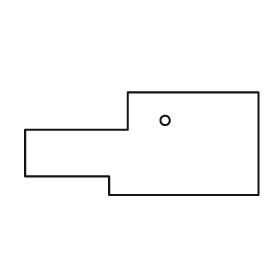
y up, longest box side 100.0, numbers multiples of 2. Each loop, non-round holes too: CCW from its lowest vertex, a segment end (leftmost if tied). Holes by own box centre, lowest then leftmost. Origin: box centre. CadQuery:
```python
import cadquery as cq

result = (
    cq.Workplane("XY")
    .moveTo(-14.0, -22.0)
    .lineTo(50.0, -22.0)
    .lineTo(50.0, 22.0)
    .lineTo(-6.0, 22.0)
    .lineTo(-6.0, 6.0)
    .lineTo(-50.0, 6.0)
    .lineTo(-50.0, -14.0)
    .lineTo(-14.0, -14.0)
    .close()
    .moveTo(10.0, 10.0)
    .circle(2.0)
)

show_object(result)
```